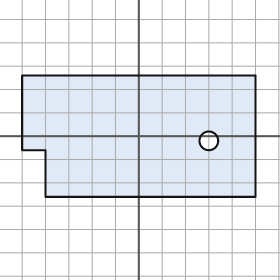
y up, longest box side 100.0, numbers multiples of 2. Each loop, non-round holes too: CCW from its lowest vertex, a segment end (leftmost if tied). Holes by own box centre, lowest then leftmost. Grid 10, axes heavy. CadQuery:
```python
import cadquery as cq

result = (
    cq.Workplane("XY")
    .moveTo(-40.0, -26.0)
    .lineTo(50.0, -26.0)
    .lineTo(50.0, 26.0)
    .lineTo(-50.0, 26.0)
    .lineTo(-50.0, -6.0)
    .lineTo(-40.0, -6.0)
    .close()
    .moveTo(30.0, -2.0)
    .circle(4.0)
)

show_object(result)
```